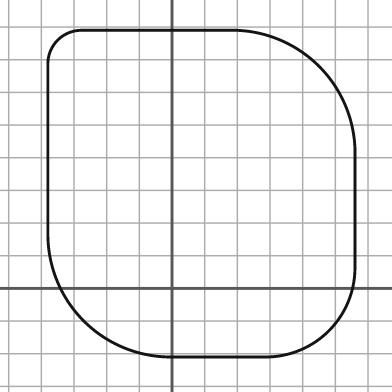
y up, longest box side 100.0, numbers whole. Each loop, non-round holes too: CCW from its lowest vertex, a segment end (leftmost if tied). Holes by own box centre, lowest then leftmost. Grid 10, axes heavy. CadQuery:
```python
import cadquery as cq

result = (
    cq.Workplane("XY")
    .moveTo(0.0, -21.0)
    .lineTo(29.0, -21.0)
    .threePointArc((48.0, -13.0), (56.0, 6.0))
    .lineTo(56.0, 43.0)
    .threePointArc((45.0, 68.0), (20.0, 79.0))
    .lineTo(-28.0, 79.0)
    .threePointArc((-35.0, 76.0), (-38.0, 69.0))
    .lineTo(-38.0, 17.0)
    .threePointArc((-27.0, -10.0), (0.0, -21.0))
    .close()
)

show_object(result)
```